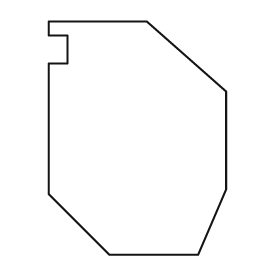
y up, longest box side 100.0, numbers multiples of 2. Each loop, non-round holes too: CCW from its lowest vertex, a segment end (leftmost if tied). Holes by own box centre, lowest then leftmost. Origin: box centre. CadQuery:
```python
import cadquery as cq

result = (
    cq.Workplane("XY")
    .moveTo(-12.0, -50.0)
    .lineTo(26.0, -50.0)
    .lineTo(38.0, -22.0)
    .lineTo(38.0, 20.0)
    .lineTo(4.0, 50.0)
    .lineTo(-38.0, 50.0)
    .lineTo(-38.0, 44.0)
    .lineTo(-30.0, 44.0)
    .lineTo(-30.0, 32.0)
    .lineTo(-38.0, 32.0)
    .lineTo(-38.0, -24.0)
    .close()
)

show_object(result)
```